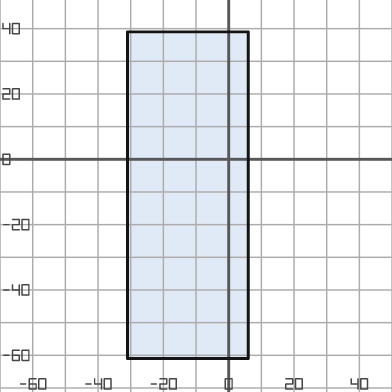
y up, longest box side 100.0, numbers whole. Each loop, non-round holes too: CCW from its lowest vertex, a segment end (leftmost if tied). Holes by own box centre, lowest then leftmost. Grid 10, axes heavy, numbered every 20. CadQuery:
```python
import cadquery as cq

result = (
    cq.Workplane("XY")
    .moveTo(-31.0, -61.0)
    .lineTo(6.0, -61.0)
    .lineTo(6.0, 39.0)
    .lineTo(-31.0, 39.0)
    .close()
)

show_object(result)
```